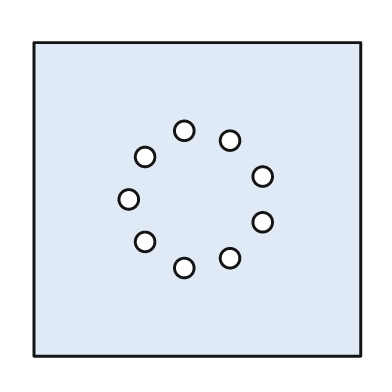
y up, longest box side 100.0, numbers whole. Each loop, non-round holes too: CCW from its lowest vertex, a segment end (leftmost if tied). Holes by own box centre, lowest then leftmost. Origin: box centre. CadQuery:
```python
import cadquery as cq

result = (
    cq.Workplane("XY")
    .moveTo(-50.0, -48.0)
    .lineTo(50.0, -48.0)
    .lineTo(50.0, 48.0)
    .lineTo(-50.0, 48.0)
    .close()
    .moveTo(-4.0, -21.0)
    .circle(3.0)
    .moveTo(10.0, -18.0)
    .circle(3.0)
    .moveTo(-16.0, -13.0)
    .circle(3.0)
    .moveTo(20.0, -7.0)
    .circle(3.0)
    .moveTo(-21.0, 0.0)
    .circle(3.0)
    .moveTo(20.0, 7.0)
    .circle(3.0)
    .moveTo(-16.0, 13.0)
    .circle(3.0)
    .moveTo(10.0, 18.0)
    .circle(3.0)
    .moveTo(-4.0, 21.0)
    .circle(3.0)
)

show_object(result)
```